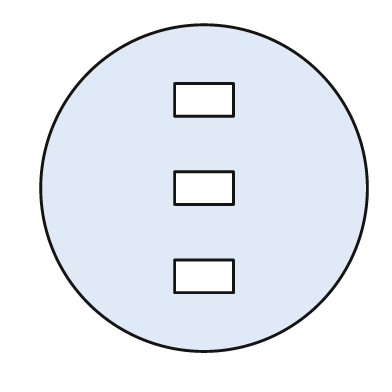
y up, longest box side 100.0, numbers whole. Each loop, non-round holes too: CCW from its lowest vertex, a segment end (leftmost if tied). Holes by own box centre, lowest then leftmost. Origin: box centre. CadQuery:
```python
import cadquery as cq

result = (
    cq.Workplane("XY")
    .moveTo(0.0, 0.0)
    .circle(50.0)
    .moveTo(-9.0, -32.0)
    .lineTo(9.0, -32.0)
    .lineTo(9.0, -22.0)
    .lineTo(-9.0, -22.0)
    .close()
    .moveTo(-9.0, -5.0)
    .lineTo(9.0, -5.0)
    .lineTo(9.0, 5.0)
    .lineTo(-9.0, 5.0)
    .close()
    .moveTo(-9.0, 22.0)
    .lineTo(9.0, 22.0)
    .lineTo(9.0, 32.0)
    .lineTo(-9.0, 32.0)
    .close()
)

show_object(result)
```